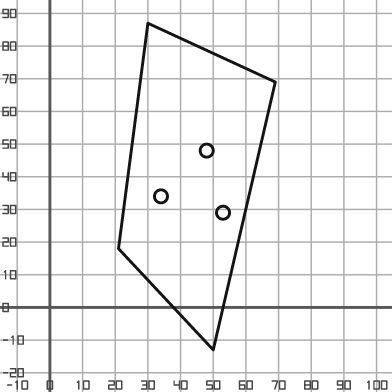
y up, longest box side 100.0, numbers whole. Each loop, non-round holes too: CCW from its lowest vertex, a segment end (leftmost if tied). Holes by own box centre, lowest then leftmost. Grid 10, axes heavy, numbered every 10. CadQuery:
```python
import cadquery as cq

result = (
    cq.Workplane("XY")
    .moveTo(50.0, -13.0)
    .lineTo(69.0, 69.0)
    .lineTo(30.0, 87.0)
    .lineTo(21.0, 18.0)
    .close()
    .moveTo(53.0, 29.0)
    .circle(2.0)
    .moveTo(34.0, 34.0)
    .circle(2.0)
    .moveTo(48.0, 48.0)
    .circle(2.0)
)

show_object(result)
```